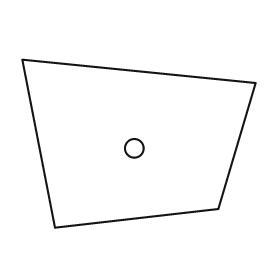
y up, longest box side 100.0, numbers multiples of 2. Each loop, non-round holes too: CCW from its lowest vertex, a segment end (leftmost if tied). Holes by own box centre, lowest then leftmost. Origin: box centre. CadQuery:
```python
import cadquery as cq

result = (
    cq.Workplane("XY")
    .moveTo(-36.0, -36.0)
    .lineTo(34.0, -28.0)
    .lineTo(50.0, 26.0)
    .lineTo(-50.0, 36.0)
    .close()
    .moveTo(-2.0, -2.0)
    .circle(4.0)
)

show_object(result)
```